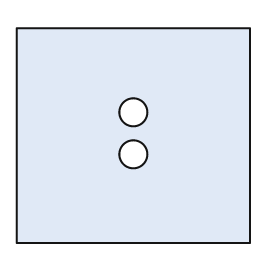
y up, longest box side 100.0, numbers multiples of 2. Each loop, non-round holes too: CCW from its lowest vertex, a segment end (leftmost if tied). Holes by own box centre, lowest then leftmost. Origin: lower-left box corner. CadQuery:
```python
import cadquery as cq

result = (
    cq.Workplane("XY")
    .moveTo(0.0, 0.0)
    .lineTo(100.0, 0.0)
    .lineTo(100.0, 92.0)
    .lineTo(0.0, 92.0)
    .close()
    .moveTo(50.0, 38.0)
    .circle(6.0)
    .moveTo(50.0, 56.0)
    .circle(6.0)
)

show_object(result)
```